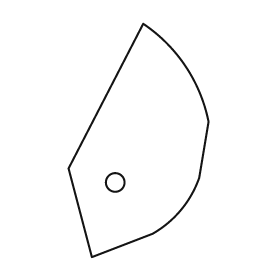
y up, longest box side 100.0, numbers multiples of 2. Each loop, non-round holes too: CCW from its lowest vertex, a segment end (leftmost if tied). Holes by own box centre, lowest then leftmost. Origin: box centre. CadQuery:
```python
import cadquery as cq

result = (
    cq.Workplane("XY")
    .moveTo(-20.0, -50.0)
    .lineTo(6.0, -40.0)
    .threePointArc((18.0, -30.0), (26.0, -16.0))
    .lineTo(30.0, 8.0)
    .threePointArc((20.0, 32.0), (2.0, 50.0))
    .lineTo(-30.0, -12.0)
    .close()
    .moveTo(-10.0, -18.0)
    .circle(4.0)
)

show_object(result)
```